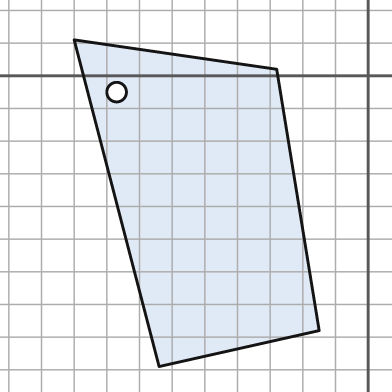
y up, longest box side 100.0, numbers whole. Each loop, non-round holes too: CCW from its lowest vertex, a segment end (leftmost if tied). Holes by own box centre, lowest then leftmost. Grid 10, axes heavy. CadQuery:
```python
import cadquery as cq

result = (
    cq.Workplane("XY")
    .moveTo(-64.0, -89.0)
    .lineTo(-15.0, -78.0)
    .lineTo(-28.0, 2.0)
    .lineTo(-90.0, 11.0)
    .close()
    .moveTo(-77.0, -5.0)
    .circle(3.0)
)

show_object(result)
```